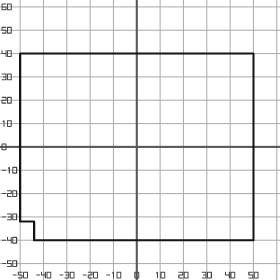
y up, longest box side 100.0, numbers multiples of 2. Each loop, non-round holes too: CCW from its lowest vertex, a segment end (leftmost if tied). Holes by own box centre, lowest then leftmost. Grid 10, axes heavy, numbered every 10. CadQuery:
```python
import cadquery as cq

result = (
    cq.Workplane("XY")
    .moveTo(-44.0, -40.0)
    .lineTo(50.0, -40.0)
    .lineTo(50.0, 40.0)
    .lineTo(-50.0, 40.0)
    .lineTo(-50.0, -32.0)
    .lineTo(-44.0, -32.0)
    .close()
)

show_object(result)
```